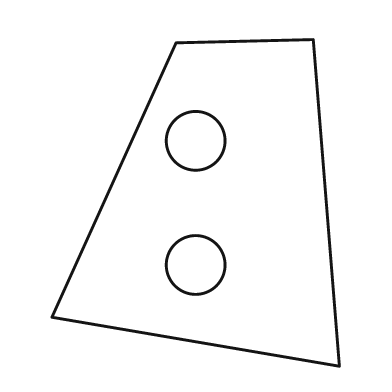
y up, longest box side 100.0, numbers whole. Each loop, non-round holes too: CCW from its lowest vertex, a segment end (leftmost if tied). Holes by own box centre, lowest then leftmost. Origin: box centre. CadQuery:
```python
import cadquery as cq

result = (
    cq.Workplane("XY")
    .moveTo(44.0, -50.0)
    .lineTo(36.0, 50.0)
    .lineTo(-6.0, 49.0)
    .lineTo(-44.0, -35.0)
    .close()
    .moveTo(0.0, -19.0)
    .circle(9.0)
    .moveTo(0.0, 19.0)
    .circle(9.0)
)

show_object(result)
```